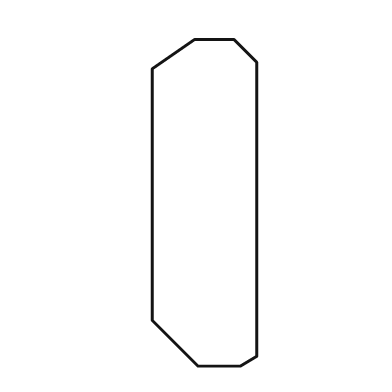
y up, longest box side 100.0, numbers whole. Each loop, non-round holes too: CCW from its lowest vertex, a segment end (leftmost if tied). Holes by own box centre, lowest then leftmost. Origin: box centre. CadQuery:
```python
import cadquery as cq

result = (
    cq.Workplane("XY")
    .moveTo(-2.0, -50.0)
    .lineTo(11.0, -50.0)
    .lineTo(16.0, -47.0)
    .lineTo(16.0, 43.0)
    .lineTo(9.0, 50.0)
    .lineTo(-3.0, 50.0)
    .lineTo(-16.0, 41.0)
    .lineTo(-16.0, -36.0)
    .close()
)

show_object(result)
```